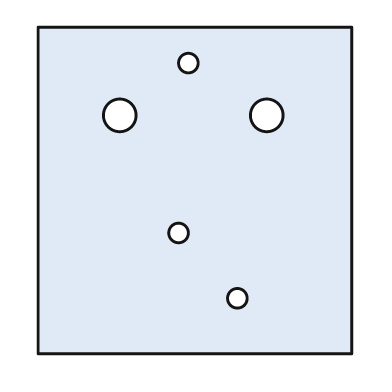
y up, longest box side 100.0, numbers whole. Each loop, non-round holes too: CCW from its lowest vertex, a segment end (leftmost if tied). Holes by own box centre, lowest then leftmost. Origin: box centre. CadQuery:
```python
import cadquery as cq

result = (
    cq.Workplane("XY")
    .moveTo(-48.0, -50.0)
    .lineTo(48.0, -50.0)
    .lineTo(48.0, 50.0)
    .lineTo(-48.0, 50.0)
    .close()
    .moveTo(13.0, -33.0)
    .circle(3.0)
    .moveTo(-5.0, -13.0)
    .circle(3.0)
    .moveTo(-23.0, 23.0)
    .circle(5.0)
    .moveTo(22.0, 23.0)
    .circle(5.0)
    .moveTo(-2.0, 39.0)
    .circle(3.0)
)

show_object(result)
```